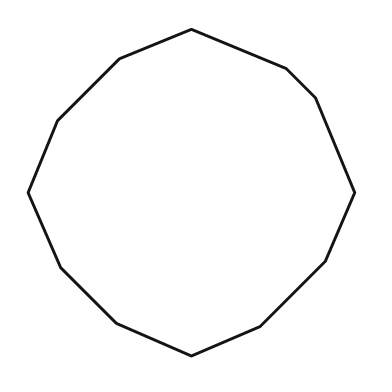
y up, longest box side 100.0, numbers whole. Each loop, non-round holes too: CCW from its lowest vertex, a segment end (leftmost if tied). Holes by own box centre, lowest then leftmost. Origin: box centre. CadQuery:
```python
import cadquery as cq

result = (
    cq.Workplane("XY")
    .moveTo(0.0, -50.0)
    .lineTo(21.0, -41.0)
    .lineTo(41.0, -21.0)
    .lineTo(50.0, 0.0)
    .lineTo(38.0, 29.0)
    .lineTo(29.0, 38.0)
    .lineTo(0.0, 50.0)
    .lineTo(-22.0, 41.0)
    .lineTo(-41.0, 22.0)
    .lineTo(-50.0, 0.0)
    .lineTo(-40.0, -23.0)
    .lineTo(-23.0, -40.0)
    .close()
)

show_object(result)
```